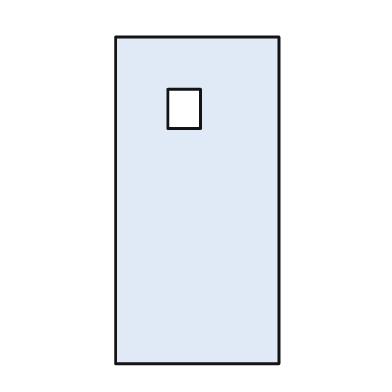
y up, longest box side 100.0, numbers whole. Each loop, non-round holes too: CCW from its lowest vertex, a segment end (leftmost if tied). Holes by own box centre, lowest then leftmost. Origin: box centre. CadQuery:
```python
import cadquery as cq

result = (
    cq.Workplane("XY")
    .moveTo(-25.0, -50.0)
    .lineTo(25.0, -50.0)
    .lineTo(25.0, 50.0)
    .lineTo(-25.0, 50.0)
    .close()
    .moveTo(-9.0, 22.0)
    .lineTo(1.0, 22.0)
    .lineTo(1.0, 34.0)
    .lineTo(-9.0, 34.0)
    .close()
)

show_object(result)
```